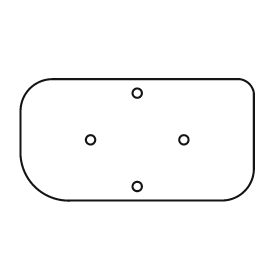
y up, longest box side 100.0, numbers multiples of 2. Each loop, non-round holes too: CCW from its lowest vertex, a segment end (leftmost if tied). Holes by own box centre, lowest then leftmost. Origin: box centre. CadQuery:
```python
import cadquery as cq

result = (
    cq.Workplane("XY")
    .moveTo(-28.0, -26.0)
    .lineTo(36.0, -26.0)
    .threePointArc((46.0, -22.0), (50.0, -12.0))
    .lineTo(50.0, 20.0)
    .threePointArc((48.0, 24.0), (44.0, 26.0))
    .lineTo(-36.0, 26.0)
    .threePointArc((-46.0, 22.0), (-50.0, 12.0))
    .lineTo(-50.0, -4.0)
    .threePointArc((-44.0, -20.0), (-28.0, -26.0))
    .close()
    .moveTo(0.0, -20.0)
    .circle(2.0)
    .moveTo(-20.0, 0.0)
    .circle(2.0)
    .moveTo(20.0, 0.0)
    .circle(2.0)
    .moveTo(0.0, 20.0)
    .circle(2.0)
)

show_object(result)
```